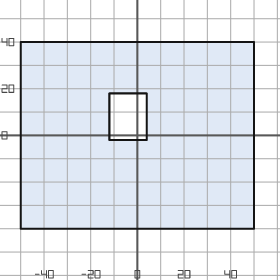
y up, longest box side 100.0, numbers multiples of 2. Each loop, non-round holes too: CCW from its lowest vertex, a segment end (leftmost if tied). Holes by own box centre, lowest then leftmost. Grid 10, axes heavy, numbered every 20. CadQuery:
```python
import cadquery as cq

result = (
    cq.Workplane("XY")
    .moveTo(-50.0, -40.0)
    .lineTo(50.0, -40.0)
    .lineTo(50.0, 40.0)
    .lineTo(-50.0, 40.0)
    .close()
    .moveTo(-12.0, -2.0)
    .lineTo(4.0, -2.0)
    .lineTo(4.0, 18.0)
    .lineTo(-12.0, 18.0)
    .close()
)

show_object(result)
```